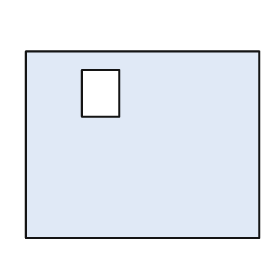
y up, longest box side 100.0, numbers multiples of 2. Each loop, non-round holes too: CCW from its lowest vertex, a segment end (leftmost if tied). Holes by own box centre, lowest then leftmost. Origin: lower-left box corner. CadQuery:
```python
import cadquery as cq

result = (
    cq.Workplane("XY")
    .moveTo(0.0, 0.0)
    .lineTo(100.0, 0.0)
    .lineTo(100.0, 80.0)
    .lineTo(0.0, 80.0)
    .close()
    .moveTo(24.0, 52.0)
    .lineTo(40.0, 52.0)
    .lineTo(40.0, 72.0)
    .lineTo(24.0, 72.0)
    .close()
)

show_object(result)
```